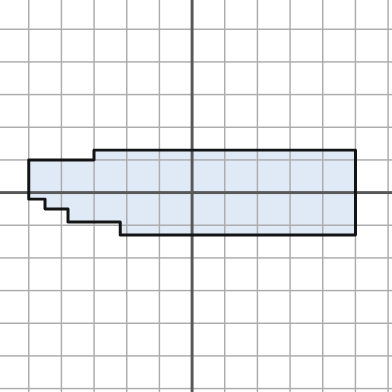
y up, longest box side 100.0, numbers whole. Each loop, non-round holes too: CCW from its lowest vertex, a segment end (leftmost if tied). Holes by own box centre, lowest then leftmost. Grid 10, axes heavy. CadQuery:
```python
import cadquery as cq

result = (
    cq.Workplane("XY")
    .moveTo(-22.0, -13.0)
    .lineTo(50.0, -13.0)
    .lineTo(50.0, 13.0)
    .lineTo(-30.0, 13.0)
    .lineTo(-30.0, 10.0)
    .lineTo(-50.0, 10.0)
    .lineTo(-50.0, -2.0)
    .lineTo(-45.0, -2.0)
    .lineTo(-45.0, -5.0)
    .lineTo(-38.0, -5.0)
    .lineTo(-38.0, -9.0)
    .lineTo(-22.0, -9.0)
    .close()
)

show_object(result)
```